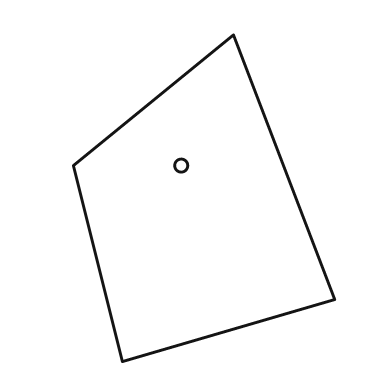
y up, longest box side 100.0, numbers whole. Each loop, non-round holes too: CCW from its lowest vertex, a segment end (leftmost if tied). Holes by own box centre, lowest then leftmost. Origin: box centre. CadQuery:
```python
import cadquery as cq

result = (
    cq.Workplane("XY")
    .moveTo(-25.0, -50.0)
    .lineTo(40.0, -31.0)
    .lineTo(9.0, 50.0)
    .lineTo(-40.0, 10.0)
    .close()
    .moveTo(-7.0, 10.0)
    .circle(2.0)
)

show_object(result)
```